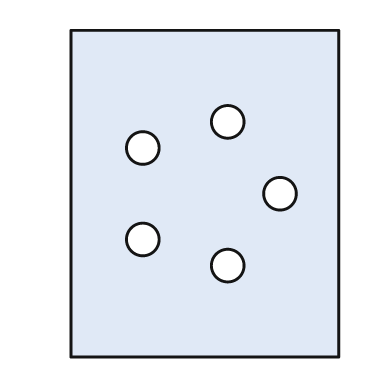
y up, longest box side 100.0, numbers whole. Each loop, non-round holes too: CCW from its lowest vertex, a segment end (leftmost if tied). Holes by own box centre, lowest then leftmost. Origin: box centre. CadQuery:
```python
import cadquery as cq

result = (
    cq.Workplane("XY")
    .moveTo(-41.0, -50.0)
    .lineTo(41.0, -50.0)
    .lineTo(41.0, 50.0)
    .lineTo(-41.0, 50.0)
    .close()
    .moveTo(7.0, -22.0)
    .circle(5.0)
    .moveTo(-19.0, -14.0)
    .circle(5.0)
    .moveTo(23.0, 0.0)
    .circle(5.0)
    .moveTo(-19.0, 14.0)
    .circle(5.0)
    .moveTo(7.0, 22.0)
    .circle(5.0)
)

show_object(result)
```